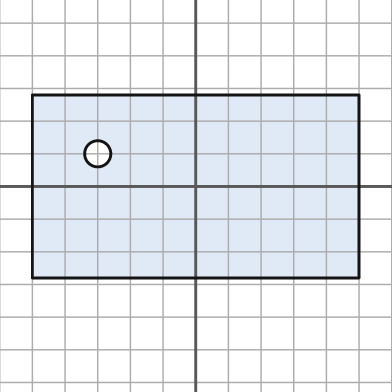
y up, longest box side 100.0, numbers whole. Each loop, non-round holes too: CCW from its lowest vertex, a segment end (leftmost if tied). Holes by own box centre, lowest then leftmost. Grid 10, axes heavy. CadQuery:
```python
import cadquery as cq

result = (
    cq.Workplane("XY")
    .moveTo(-50.0, -28.0)
    .lineTo(50.0, -28.0)
    .lineTo(50.0, 28.0)
    .lineTo(-50.0, 28.0)
    .close()
    .moveTo(-30.0, 10.0)
    .circle(4.0)
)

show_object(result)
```